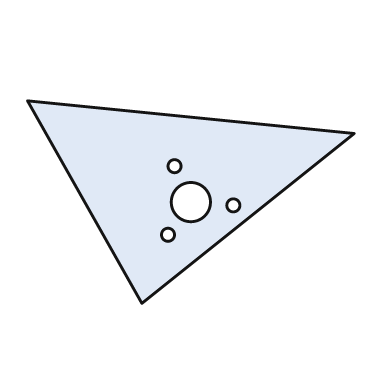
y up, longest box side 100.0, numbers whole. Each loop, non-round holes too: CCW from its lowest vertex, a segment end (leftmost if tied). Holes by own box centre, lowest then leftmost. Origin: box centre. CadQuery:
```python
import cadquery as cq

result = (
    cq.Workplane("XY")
    .moveTo(-15.0, -31.0)
    .lineTo(50.0, 21.0)
    .lineTo(-50.0, 31.0)
    .close()
    .moveTo(-7.0, -10.0)
    .circle(2.0)
    .moveTo(13.0, -1.0)
    .circle(2.0)
    .moveTo(0.0, 0.0)
    .circle(6.0)
    .moveTo(-5.0, 11.0)
    .circle(2.0)
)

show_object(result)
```